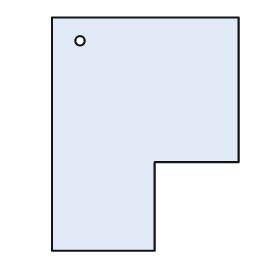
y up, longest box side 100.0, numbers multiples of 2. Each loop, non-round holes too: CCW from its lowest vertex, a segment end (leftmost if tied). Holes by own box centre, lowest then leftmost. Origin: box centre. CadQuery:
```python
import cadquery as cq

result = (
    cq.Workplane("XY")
    .moveTo(-40.0, -50.0)
    .lineTo(4.0, -50.0)
    .lineTo(4.0, -12.0)
    .lineTo(40.0, -12.0)
    .lineTo(40.0, 50.0)
    .lineTo(-40.0, 50.0)
    .close()
    .moveTo(-28.0, 40.0)
    .circle(2.0)
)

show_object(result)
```